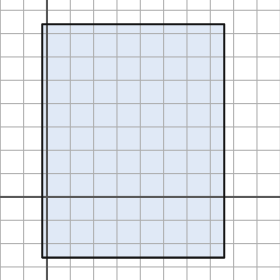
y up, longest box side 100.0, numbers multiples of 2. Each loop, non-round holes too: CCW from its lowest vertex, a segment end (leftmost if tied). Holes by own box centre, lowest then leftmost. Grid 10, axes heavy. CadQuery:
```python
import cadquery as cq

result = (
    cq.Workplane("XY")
    .moveTo(-2.0, -26.0)
    .lineTo(76.0, -26.0)
    .lineTo(76.0, 74.0)
    .lineTo(-2.0, 74.0)
    .close()
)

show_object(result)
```